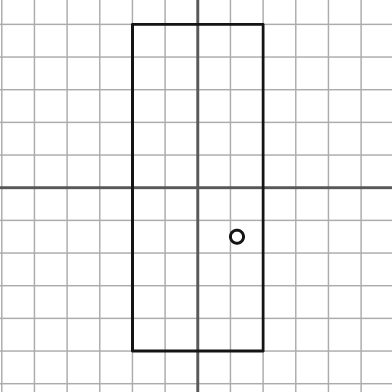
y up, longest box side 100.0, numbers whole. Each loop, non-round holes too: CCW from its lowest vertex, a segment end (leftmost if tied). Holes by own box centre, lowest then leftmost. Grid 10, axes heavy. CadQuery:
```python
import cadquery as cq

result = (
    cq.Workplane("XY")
    .moveTo(-20.0, -50.0)
    .lineTo(20.0, -50.0)
    .lineTo(20.0, 50.0)
    .lineTo(-20.0, 50.0)
    .close()
    .moveTo(12.0, -15.0)
    .circle(2.0)
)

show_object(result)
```